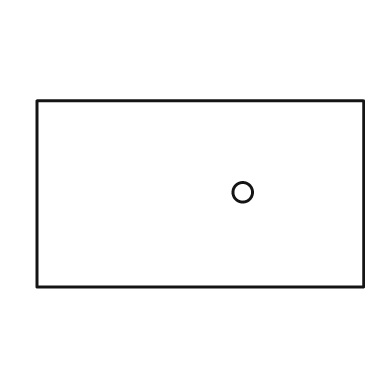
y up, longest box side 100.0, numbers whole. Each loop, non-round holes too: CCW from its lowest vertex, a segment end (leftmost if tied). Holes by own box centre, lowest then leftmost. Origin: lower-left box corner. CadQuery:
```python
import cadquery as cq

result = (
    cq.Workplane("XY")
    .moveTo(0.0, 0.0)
    .lineTo(100.0, 0.0)
    .lineTo(100.0, 57.0)
    .lineTo(0.0, 57.0)
    .close()
    .moveTo(63.0, 29.0)
    .circle(3.0)
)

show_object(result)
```